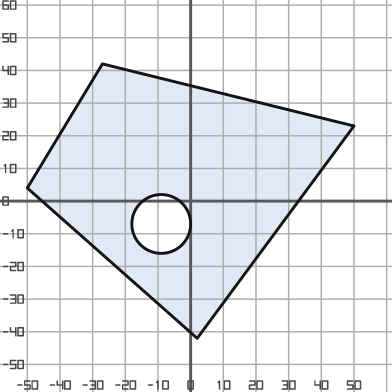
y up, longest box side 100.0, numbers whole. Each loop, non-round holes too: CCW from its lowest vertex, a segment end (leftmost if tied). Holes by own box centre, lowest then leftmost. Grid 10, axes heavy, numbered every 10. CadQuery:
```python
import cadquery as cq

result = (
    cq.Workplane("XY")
    .moveTo(2.0, -42.0)
    .lineTo(50.0, 23.0)
    .lineTo(-27.0, 42.0)
    .lineTo(-50.0, 4.0)
    .close()
    .moveTo(-9.0, -7.0)
    .circle(9.0)
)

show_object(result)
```